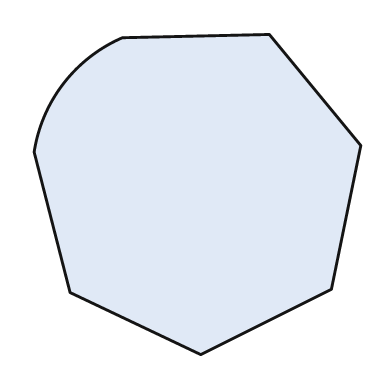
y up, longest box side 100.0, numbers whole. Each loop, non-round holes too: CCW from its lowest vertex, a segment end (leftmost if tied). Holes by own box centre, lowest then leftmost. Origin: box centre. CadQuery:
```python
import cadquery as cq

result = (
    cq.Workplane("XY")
    .moveTo(1.0, -49.0)
    .lineTo(41.0, -29.0)
    .lineTo(50.0, 15.0)
    .lineTo(22.0, 49.0)
    .lineTo(-23.0, 48.0)
    .threePointArc((-41.0, 34.0), (-50.0, 13.0))
    .lineTo(-39.0, -30.0)
    .close()
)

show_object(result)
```